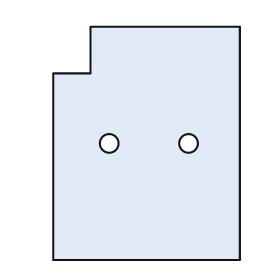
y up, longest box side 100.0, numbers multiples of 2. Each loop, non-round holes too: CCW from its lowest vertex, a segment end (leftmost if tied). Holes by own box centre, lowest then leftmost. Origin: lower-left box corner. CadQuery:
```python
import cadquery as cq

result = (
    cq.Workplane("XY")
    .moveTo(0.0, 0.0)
    .lineTo(80.0, 0.0)
    .lineTo(80.0, 100.0)
    .lineTo(16.0, 100.0)
    .lineTo(16.0, 80.0)
    .lineTo(0.0, 80.0)
    .close()
    .moveTo(24.0, 50.0)
    .circle(4.0)
    .moveTo(58.0, 50.0)
    .circle(4.0)
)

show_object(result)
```